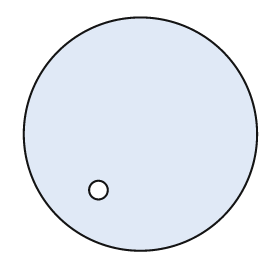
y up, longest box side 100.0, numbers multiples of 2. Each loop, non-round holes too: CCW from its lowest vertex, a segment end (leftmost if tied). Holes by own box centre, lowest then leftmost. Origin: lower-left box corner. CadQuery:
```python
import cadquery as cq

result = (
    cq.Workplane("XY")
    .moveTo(50.0, 50.0)
    .circle(50.0)
    .moveTo(32.0, 26.0)
    .circle(4.0)
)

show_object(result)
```